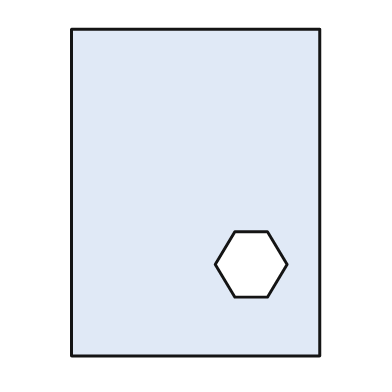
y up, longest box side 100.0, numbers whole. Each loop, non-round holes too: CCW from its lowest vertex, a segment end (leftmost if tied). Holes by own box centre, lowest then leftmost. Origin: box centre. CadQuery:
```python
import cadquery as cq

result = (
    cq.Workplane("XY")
    .moveTo(-38.0, -50.0)
    .lineTo(38.0, -50.0)
    .lineTo(38.0, 50.0)
    .lineTo(-38.0, 50.0)
    .close()
    .moveTo(12.0, -32.0)
    .lineTo(22.0, -32.0)
    .lineTo(28.0, -22.0)
    .lineTo(22.0, -12.0)
    .lineTo(12.0, -12.0)
    .lineTo(6.0, -22.0)
    .close()
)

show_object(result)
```